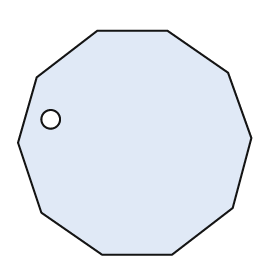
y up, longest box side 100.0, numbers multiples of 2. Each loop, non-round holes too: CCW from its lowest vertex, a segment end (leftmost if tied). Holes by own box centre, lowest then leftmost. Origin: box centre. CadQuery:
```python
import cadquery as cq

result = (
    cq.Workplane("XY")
    .moveTo(-14.0, -48.0)
    .lineTo(16.0, -48.0)
    .lineTo(42.0, -28.0)
    .lineTo(50.0, 2.0)
    .lineTo(40.0, 30.0)
    .lineTo(14.0, 48.0)
    .lineTo(-16.0, 48.0)
    .lineTo(-42.0, 28.0)
    .lineTo(-50.0, 0.0)
    .lineTo(-40.0, -30.0)
    .close()
    .moveTo(-36.0, 10.0)
    .circle(4.0)
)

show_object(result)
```